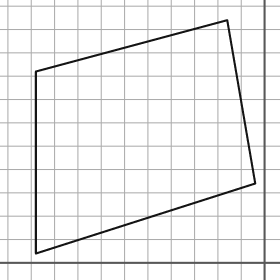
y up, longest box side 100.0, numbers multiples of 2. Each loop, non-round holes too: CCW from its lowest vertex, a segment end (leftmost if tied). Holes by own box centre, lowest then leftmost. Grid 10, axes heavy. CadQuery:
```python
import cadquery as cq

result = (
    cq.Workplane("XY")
    .moveTo(-98.0, 4.0)
    .lineTo(-4.0, 34.0)
    .lineTo(-16.0, 104.0)
    .lineTo(-98.0, 82.0)
    .close()
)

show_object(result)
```